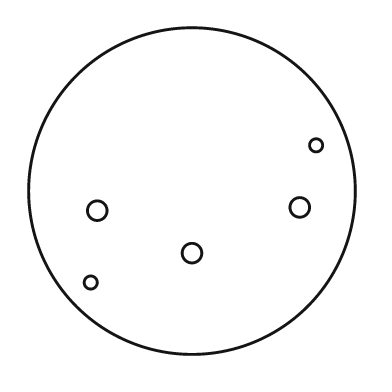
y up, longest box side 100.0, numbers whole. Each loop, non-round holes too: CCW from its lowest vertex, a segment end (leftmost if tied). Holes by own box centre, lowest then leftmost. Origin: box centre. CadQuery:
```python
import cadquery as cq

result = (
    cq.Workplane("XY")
    .moveTo(0.0, 0.0)
    .circle(50.0)
    .moveTo(-31.0, -28.0)
    .circle(2.0)
    .moveTo(0.0, -19.0)
    .circle(3.0)
    .moveTo(-29.0, -6.0)
    .circle(3.0)
    .moveTo(33.0, -5.0)
    .circle(3.0)
    .moveTo(38.0, 14.0)
    .circle(2.0)
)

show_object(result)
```